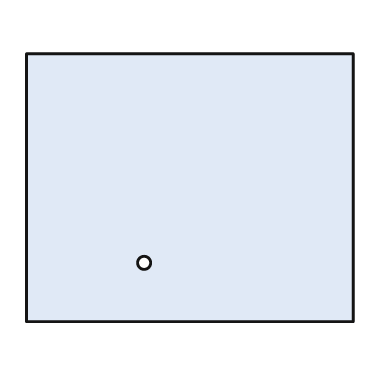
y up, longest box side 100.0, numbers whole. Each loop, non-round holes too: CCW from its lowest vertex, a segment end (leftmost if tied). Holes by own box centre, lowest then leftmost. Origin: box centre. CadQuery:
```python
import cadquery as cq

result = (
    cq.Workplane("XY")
    .moveTo(-50.0, -41.0)
    .lineTo(50.0, -41.0)
    .lineTo(50.0, 41.0)
    .lineTo(-50.0, 41.0)
    .close()
    .moveTo(-14.0, -23.0)
    .circle(2.0)
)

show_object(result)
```